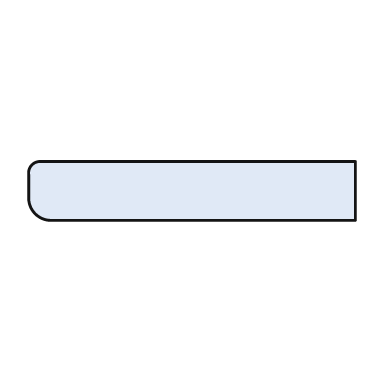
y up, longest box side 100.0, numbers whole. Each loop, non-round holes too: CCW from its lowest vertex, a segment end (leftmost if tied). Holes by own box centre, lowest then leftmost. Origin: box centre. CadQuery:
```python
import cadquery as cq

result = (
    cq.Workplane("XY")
    .moveTo(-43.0, -9.0)
    .lineTo(50.0, -9.0)
    .lineTo(50.0, 9.0)
    .lineTo(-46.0, 9.0)
    .threePointArc((-49.0, 8.0), (-50.0, 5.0))
    .lineTo(-50.0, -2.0)
    .threePointArc((-48.0, -7.0), (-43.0, -9.0))
    .close()
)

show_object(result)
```